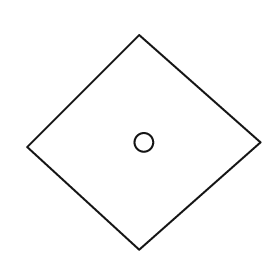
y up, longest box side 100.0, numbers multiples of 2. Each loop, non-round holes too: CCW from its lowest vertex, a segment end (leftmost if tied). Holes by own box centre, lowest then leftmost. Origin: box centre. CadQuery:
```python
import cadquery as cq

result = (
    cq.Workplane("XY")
    .moveTo(-2.0, -46.0)
    .lineTo(50.0, 0.0)
    .lineTo(-2.0, 46.0)
    .lineTo(-50.0, -2.0)
    .close()
    .moveTo(0.0, 0.0)
    .circle(4.0)
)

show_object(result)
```